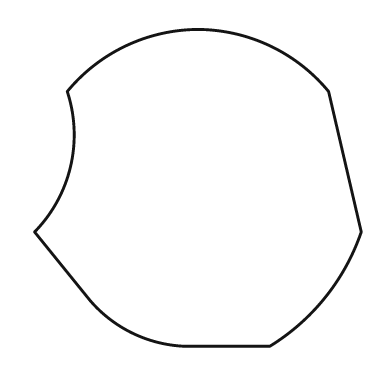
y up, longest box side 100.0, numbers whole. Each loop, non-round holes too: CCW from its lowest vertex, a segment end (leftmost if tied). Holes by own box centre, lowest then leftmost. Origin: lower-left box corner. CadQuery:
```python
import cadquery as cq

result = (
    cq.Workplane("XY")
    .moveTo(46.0, 0.0)
    .lineTo(72.0, 0.0)
    .threePointArc((89.0, 15.0), (100.0, 35.0))
    .lineTo(90.0, 78.0)
    .threePointArc((72.0, 92.0), (50.0, 97.0))
    .threePointArc((28.0, 92.0), (10.0, 78.0))
    .threePointArc((11.0, 55.0), (0.0, 35.0))
    .lineTo(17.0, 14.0)
    .threePointArc((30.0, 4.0), (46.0, 0.0))
    .close()
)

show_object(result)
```